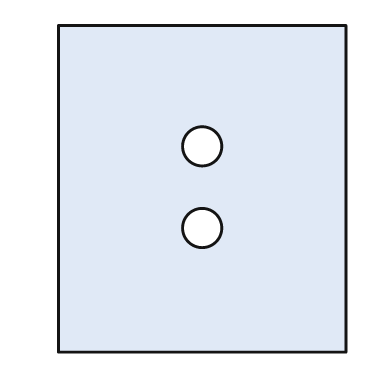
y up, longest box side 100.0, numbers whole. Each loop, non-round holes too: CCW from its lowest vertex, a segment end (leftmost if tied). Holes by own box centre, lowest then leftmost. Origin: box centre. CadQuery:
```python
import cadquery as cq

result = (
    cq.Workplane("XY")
    .moveTo(-44.0, -50.0)
    .lineTo(44.0, -50.0)
    .lineTo(44.0, 50.0)
    .lineTo(-44.0, 50.0)
    .close()
    .moveTo(0.0, -12.0)
    .circle(6.0)
    .moveTo(0.0, 13.0)
    .circle(6.0)
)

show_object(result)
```